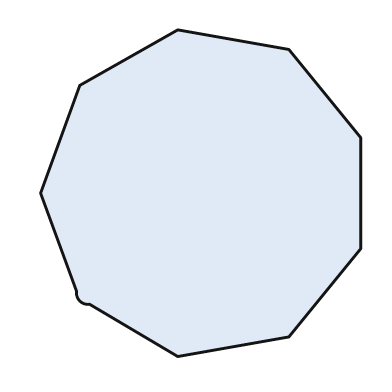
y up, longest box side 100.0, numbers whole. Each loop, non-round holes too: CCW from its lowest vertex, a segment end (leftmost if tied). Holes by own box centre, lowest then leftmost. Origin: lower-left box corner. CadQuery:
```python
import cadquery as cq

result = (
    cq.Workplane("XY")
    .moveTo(42.0, 0.0)
    .lineTo(76.0, 6.0)
    .lineTo(98.0, 33.0)
    .lineTo(98.0, 67.0)
    .lineTo(76.0, 94.0)
    .lineTo(42.0, 100.0)
    .lineTo(12.0, 83.0)
    .lineTo(0.0, 50.0)
    .lineTo(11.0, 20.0)
    .threePointArc((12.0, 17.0), (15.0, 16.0))
    .close()
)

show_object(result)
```